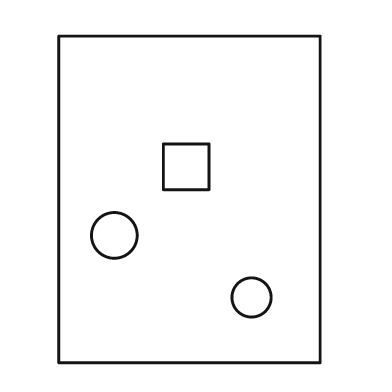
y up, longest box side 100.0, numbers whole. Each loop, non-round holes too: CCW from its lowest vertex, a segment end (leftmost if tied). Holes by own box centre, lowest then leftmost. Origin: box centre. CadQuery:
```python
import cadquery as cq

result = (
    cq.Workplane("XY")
    .moveTo(-40.0, -50.0)
    .lineTo(40.0, -50.0)
    .lineTo(40.0, 50.0)
    .lineTo(-40.0, 50.0)
    .close()
    .moveTo(19.0, -30.0)
    .circle(6.0)
    .moveTo(-23.0, -11.0)
    .circle(7.0)
    .moveTo(-8.0, 3.0)
    .lineTo(6.0, 3.0)
    .lineTo(6.0, 17.0)
    .lineTo(-8.0, 17.0)
    .close()
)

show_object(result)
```